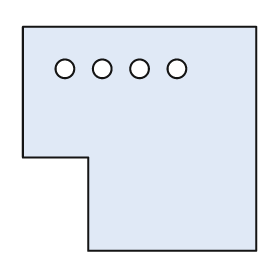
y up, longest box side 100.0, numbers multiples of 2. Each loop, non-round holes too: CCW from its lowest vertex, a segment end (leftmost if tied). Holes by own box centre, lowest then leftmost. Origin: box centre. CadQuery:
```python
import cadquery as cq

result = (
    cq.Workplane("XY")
    .moveTo(-22.0, -48.0)
    .lineTo(50.0, -48.0)
    .lineTo(50.0, 48.0)
    .lineTo(-50.0, 48.0)
    .lineTo(-50.0, -8.0)
    .lineTo(-22.0, -8.0)
    .close()
    .moveTo(-32.0, 30.0)
    .circle(4.0)
    .moveTo(-16.0, 30.0)
    .circle(4.0)
    .moveTo(0.0, 30.0)
    .circle(4.0)
    .moveTo(16.0, 30.0)
    .circle(4.0)
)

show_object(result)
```